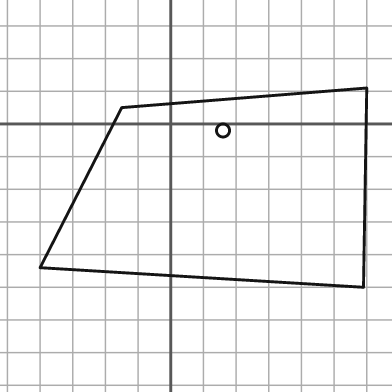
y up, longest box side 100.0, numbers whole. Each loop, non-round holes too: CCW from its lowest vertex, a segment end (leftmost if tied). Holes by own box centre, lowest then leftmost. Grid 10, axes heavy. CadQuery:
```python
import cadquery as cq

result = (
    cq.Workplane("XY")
    .moveTo(59.0, -50.0)
    .lineTo(60.0, 11.0)
    .lineTo(-15.0, 5.0)
    .lineTo(-40.0, -44.0)
    .close()
    .moveTo(16.0, -2.0)
    .circle(2.0)
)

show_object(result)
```